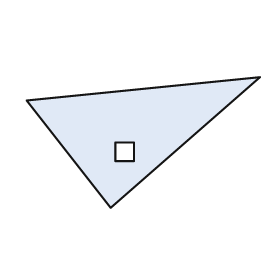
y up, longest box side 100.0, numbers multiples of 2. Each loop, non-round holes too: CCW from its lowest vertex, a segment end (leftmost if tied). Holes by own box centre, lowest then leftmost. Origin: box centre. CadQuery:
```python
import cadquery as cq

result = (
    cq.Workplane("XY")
    .moveTo(-14.0, -28.0)
    .lineTo(50.0, 28.0)
    .lineTo(-50.0, 18.0)
    .close()
    .moveTo(-12.0, -8.0)
    .lineTo(-4.0, -8.0)
    .lineTo(-4.0, 0.0)
    .lineTo(-12.0, 0.0)
    .close()
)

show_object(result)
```